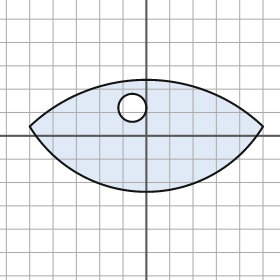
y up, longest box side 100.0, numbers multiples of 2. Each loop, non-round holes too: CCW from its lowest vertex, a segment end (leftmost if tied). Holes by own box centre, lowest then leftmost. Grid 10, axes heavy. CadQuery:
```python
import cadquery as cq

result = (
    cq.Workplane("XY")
    .moveTo(-50.0, 4.0)
    .threePointArc((0.0, -24.0), (50.0, 4.0))
    .threePointArc((0.0, 24.0), (-50.0, 4.0))
    .close()
    .moveTo(-6.0, 12.0)
    .circle(6.0)
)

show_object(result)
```